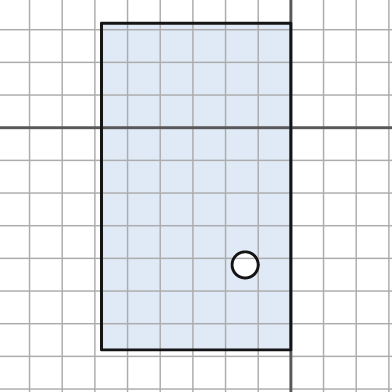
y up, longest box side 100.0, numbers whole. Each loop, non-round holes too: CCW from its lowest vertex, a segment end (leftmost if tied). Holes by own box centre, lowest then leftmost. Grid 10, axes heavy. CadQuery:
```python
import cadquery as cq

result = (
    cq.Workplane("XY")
    .moveTo(-58.0, -68.0)
    .lineTo(0.0, -68.0)
    .lineTo(0.0, 32.0)
    .lineTo(-58.0, 32.0)
    .close()
    .moveTo(-14.0, -42.0)
    .circle(4.0)
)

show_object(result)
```